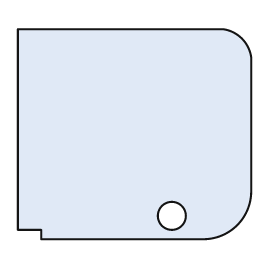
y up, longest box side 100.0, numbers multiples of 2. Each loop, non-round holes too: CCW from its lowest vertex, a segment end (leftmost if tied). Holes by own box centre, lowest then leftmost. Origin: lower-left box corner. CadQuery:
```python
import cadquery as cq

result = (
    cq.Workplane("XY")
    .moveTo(10.0, 0.0)
    .lineTo(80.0, 0.0)
    .threePointArc((94.0, 6.0), (100.0, 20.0))
    .lineTo(100.0, 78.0)
    .threePointArc((96.0, 86.0), (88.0, 90.0))
    .lineTo(0.0, 90.0)
    .lineTo(0.0, 4.0)
    .lineTo(10.0, 4.0)
    .close()
    .moveTo(66.0, 10.0)
    .circle(6.0)
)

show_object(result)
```